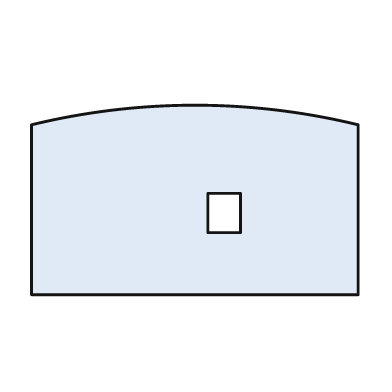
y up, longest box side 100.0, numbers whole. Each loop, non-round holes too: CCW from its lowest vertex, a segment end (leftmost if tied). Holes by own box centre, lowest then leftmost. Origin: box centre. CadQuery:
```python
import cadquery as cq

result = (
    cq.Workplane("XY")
    .moveTo(-50.0, -29.0)
    .lineTo(50.0, -29.0)
    .lineTo(50.0, 23.0)
    .threePointArc((0.0, 29.0), (-50.0, 23.0))
    .close()
    .moveTo(4.0, -10.0)
    .lineTo(14.0, -10.0)
    .lineTo(14.0, 2.0)
    .lineTo(4.0, 2.0)
    .close()
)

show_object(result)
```